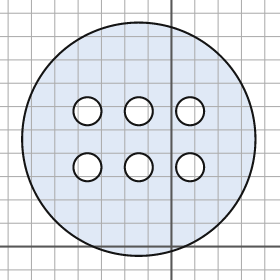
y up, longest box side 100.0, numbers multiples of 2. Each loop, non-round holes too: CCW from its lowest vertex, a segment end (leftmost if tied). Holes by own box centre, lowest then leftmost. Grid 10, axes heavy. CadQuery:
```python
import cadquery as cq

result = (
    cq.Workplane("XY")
    .moveTo(-14.0, 46.0)
    .circle(50.0)
    .moveTo(-36.0, 34.0)
    .circle(6.0)
    .moveTo(-14.0, 34.0)
    .circle(6.0)
    .moveTo(8.0, 34.0)
    .circle(6.0)
    .moveTo(-36.0, 58.0)
    .circle(6.0)
    .moveTo(-14.0, 58.0)
    .circle(6.0)
    .moveTo(8.0, 58.0)
    .circle(6.0)
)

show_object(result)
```